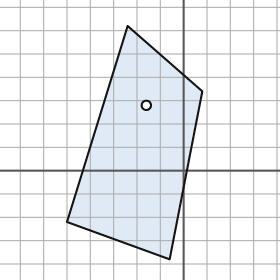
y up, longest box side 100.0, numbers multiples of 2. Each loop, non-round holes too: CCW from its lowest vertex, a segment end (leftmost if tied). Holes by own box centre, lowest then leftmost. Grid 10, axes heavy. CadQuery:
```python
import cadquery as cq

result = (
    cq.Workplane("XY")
    .moveTo(-6.0, -38.0)
    .lineTo(8.0, 34.0)
    .lineTo(-24.0, 62.0)
    .lineTo(-50.0, -22.0)
    .close()
    .moveTo(-16.0, 28.0)
    .circle(2.0)
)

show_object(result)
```